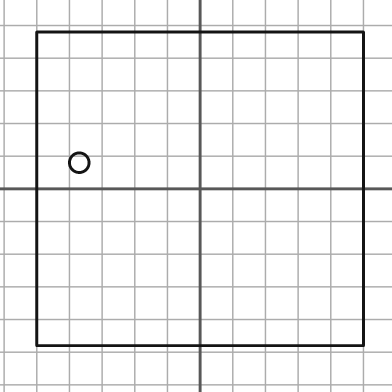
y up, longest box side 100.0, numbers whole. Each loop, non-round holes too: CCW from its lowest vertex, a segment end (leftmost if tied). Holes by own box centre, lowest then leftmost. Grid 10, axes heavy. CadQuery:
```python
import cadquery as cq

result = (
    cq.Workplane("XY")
    .moveTo(-50.0, -48.0)
    .lineTo(50.0, -48.0)
    .lineTo(50.0, 48.0)
    .lineTo(-50.0, 48.0)
    .close()
    .moveTo(-37.0, 8.0)
    .circle(3.0)
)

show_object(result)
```